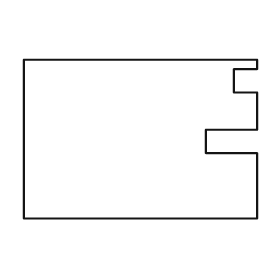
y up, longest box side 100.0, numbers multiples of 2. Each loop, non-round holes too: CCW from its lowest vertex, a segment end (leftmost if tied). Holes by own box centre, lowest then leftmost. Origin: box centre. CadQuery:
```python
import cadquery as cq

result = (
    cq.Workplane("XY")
    .moveTo(-50.0, -34.0)
    .lineTo(50.0, -34.0)
    .lineTo(50.0, -6.0)
    .lineTo(28.0, -6.0)
    .lineTo(28.0, 4.0)
    .lineTo(50.0, 4.0)
    .lineTo(50.0, 20.0)
    .lineTo(40.0, 20.0)
    .lineTo(40.0, 30.0)
    .lineTo(50.0, 30.0)
    .lineTo(50.0, 34.0)
    .lineTo(-50.0, 34.0)
    .close()
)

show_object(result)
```